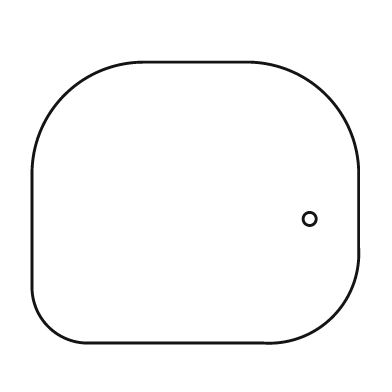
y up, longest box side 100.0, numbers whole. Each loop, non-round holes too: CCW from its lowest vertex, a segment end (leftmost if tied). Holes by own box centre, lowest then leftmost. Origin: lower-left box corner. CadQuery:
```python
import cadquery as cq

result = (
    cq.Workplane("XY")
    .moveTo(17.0, 0.0)
    .lineTo(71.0, 0.0)
    .threePointArc((92.0, 8.0), (100.0, 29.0))
    .lineTo(100.0, 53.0)
    .threePointArc((90.0, 76.0), (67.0, 86.0))
    .lineTo(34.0, 86.0)
    .threePointArc((10.0, 76.0), (0.0, 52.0))
    .lineTo(0.0, 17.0)
    .threePointArc((5.0, 5.0), (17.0, 0.0))
    .close()
    .moveTo(85.0, 38.0)
    .circle(2.0)
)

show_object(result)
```